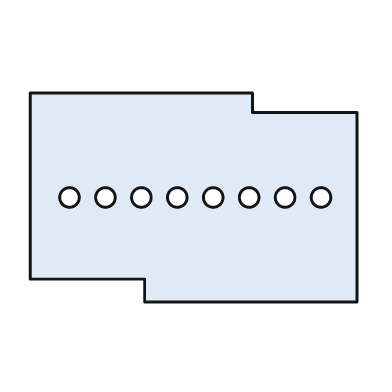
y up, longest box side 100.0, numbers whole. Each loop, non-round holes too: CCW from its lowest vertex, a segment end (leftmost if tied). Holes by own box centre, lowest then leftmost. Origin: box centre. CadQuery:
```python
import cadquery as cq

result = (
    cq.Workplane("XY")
    .moveTo(-15.0, -32.0)
    .lineTo(50.0, -32.0)
    .lineTo(50.0, 26.0)
    .lineTo(18.0, 26.0)
    .lineTo(18.0, 32.0)
    .lineTo(-50.0, 32.0)
    .lineTo(-50.0, -25.0)
    .lineTo(-15.0, -25.0)
    .close()
    .moveTo(-38.0, 0.0)
    .circle(3.0)
    .moveTo(-27.0, 0.0)
    .circle(3.0)
    .moveTo(-16.0, 0.0)
    .circle(3.0)
    .moveTo(-5.0, 0.0)
    .circle(3.0)
    .moveTo(6.0, 0.0)
    .circle(3.0)
    .moveTo(17.0, 0.0)
    .circle(3.0)
    .moveTo(28.0, 0.0)
    .circle(3.0)
    .moveTo(39.0, 0.0)
    .circle(3.0)
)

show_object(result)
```